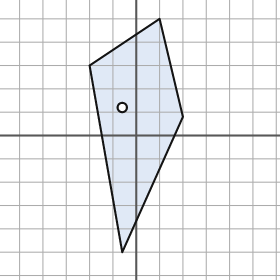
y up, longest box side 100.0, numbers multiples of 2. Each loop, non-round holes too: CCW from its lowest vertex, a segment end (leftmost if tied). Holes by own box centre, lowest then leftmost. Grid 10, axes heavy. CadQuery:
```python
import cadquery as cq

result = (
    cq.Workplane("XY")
    .moveTo(-6.0, -50.0)
    .lineTo(20.0, 8.0)
    .lineTo(10.0, 50.0)
    .lineTo(-20.0, 30.0)
    .close()
    .moveTo(-6.0, 12.0)
    .circle(2.0)
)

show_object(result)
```